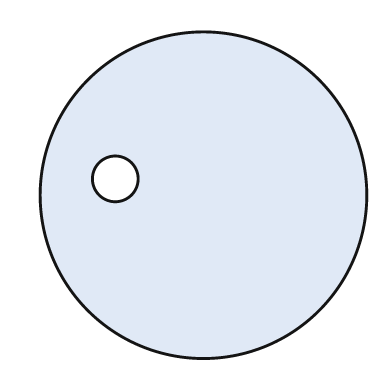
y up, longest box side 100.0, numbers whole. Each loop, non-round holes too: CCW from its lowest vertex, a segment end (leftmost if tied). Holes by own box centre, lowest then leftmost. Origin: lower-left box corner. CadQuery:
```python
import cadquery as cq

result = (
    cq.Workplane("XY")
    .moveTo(50.0, 50.0)
    .circle(50.0)
    .moveTo(23.0, 55.0)
    .circle(7.0)
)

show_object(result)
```